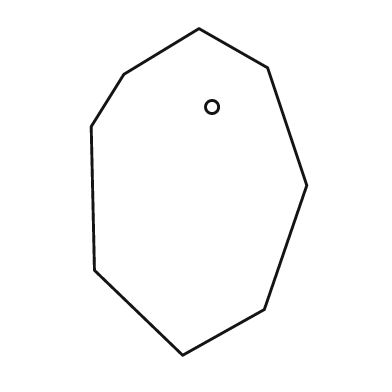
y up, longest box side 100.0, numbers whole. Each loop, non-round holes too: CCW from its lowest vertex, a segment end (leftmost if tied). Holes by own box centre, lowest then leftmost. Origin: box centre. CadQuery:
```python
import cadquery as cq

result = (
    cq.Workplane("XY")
    .moveTo(-5.0, -50.0)
    .lineTo(20.0, -36.0)
    .lineTo(33.0, 2.0)
    .lineTo(21.0, 38.0)
    .lineTo(0.0, 50.0)
    .lineTo(-23.0, 36.0)
    .lineTo(-33.0, 20.0)
    .lineTo(-32.0, -24.0)
    .close()
    .moveTo(4.0, 26.0)
    .circle(2.0)
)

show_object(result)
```